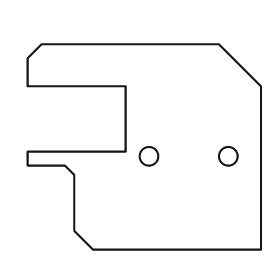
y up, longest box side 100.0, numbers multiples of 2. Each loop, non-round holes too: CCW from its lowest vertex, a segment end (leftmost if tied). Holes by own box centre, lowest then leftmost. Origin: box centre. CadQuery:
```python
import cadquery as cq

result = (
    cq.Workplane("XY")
    .moveTo(-22.0, -44.0)
    .lineTo(50.0, -44.0)
    .lineTo(50.0, 26.0)
    .lineTo(32.0, 44.0)
    .lineTo(-44.0, 44.0)
    .lineTo(-50.0, 38.0)
    .lineTo(-50.0, 26.0)
    .lineTo(-8.0, 26.0)
    .lineTo(-8.0, -2.0)
    .lineTo(-50.0, -2.0)
    .lineTo(-50.0, -8.0)
    .lineTo(-34.0, -8.0)
    .lineTo(-30.0, -12.0)
    .lineTo(-30.0, -36.0)
    .close()
    .moveTo(2.0, -4.0)
    .circle(4.0)
    .moveTo(36.0, -4.0)
    .circle(4.0)
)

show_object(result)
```